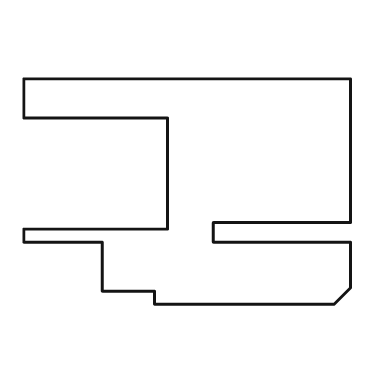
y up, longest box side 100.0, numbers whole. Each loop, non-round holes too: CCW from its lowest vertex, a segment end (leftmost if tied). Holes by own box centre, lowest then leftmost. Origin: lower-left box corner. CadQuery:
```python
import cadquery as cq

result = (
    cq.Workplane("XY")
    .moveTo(40.0, 0.0)
    .lineTo(95.0, 0.0)
    .lineTo(100.0, 5.0)
    .lineTo(100.0, 19.0)
    .lineTo(58.0, 19.0)
    .lineTo(58.0, 25.0)
    .lineTo(100.0, 25.0)
    .lineTo(100.0, 69.0)
    .lineTo(0.0, 69.0)
    .lineTo(0.0, 57.0)
    .lineTo(44.0, 57.0)
    .lineTo(44.0, 23.0)
    .lineTo(0.0, 23.0)
    .lineTo(0.0, 19.0)
    .lineTo(24.0, 19.0)
    .lineTo(24.0, 4.0)
    .lineTo(40.0, 4.0)
    .close()
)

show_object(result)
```